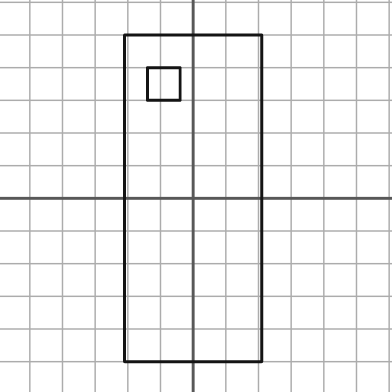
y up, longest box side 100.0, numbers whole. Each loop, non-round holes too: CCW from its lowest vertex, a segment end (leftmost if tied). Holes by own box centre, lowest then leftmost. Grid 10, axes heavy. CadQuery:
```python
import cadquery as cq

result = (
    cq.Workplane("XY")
    .moveTo(-21.0, -50.0)
    .lineTo(21.0, -50.0)
    .lineTo(21.0, 50.0)
    .lineTo(-21.0, 50.0)
    .close()
    .moveTo(-14.0, 30.0)
    .lineTo(-4.0, 30.0)
    .lineTo(-4.0, 40.0)
    .lineTo(-14.0, 40.0)
    .close()
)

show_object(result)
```